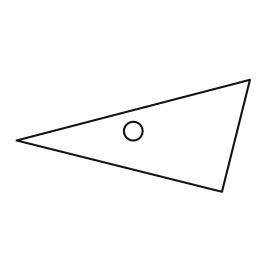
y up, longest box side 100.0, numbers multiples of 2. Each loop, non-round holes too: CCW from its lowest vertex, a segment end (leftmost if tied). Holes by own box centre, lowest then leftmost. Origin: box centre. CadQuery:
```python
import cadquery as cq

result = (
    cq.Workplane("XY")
    .moveTo(38.0, -24.0)
    .lineTo(50.0, 24.0)
    .lineTo(-50.0, -2.0)
    .close()
    .moveTo(0.0, 2.0)
    .circle(4.0)
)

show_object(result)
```